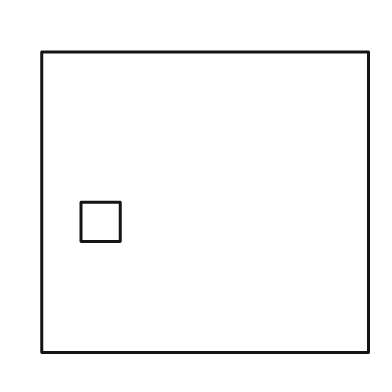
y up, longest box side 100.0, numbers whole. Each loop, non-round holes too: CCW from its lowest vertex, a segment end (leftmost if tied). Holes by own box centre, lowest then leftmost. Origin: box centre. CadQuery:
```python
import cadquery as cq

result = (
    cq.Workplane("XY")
    .moveTo(-50.0, -46.0)
    .lineTo(50.0, -46.0)
    .lineTo(50.0, 46.0)
    .lineTo(-50.0, 46.0)
    .close()
    .moveTo(-38.0, -12.0)
    .lineTo(-26.0, -12.0)
    .lineTo(-26.0, 0.0)
    .lineTo(-38.0, 0.0)
    .close()
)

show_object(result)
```